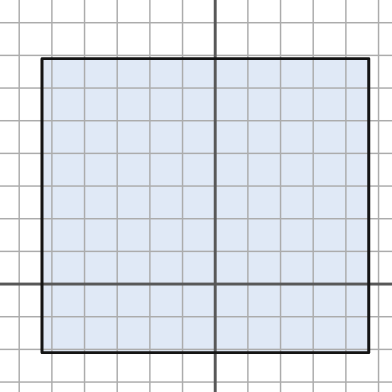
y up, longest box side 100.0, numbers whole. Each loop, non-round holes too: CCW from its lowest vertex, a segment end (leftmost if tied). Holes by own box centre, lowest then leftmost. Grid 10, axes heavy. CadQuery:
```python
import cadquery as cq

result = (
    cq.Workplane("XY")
    .moveTo(-53.0, -21.0)
    .lineTo(47.0, -21.0)
    .lineTo(47.0, 69.0)
    .lineTo(-53.0, 69.0)
    .close()
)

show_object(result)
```